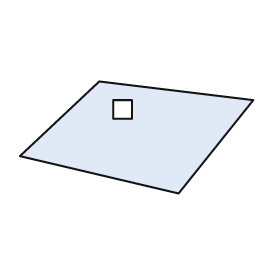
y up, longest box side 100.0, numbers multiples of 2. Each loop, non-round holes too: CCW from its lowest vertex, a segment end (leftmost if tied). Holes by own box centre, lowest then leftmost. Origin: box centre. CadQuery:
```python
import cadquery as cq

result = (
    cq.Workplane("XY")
    .moveTo(18.0, -24.0)
    .lineTo(50.0, 16.0)
    .lineTo(-16.0, 24.0)
    .lineTo(-50.0, -8.0)
    .close()
    .moveTo(-10.0, 8.0)
    .lineTo(-2.0, 8.0)
    .lineTo(-2.0, 16.0)
    .lineTo(-10.0, 16.0)
    .close()
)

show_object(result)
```